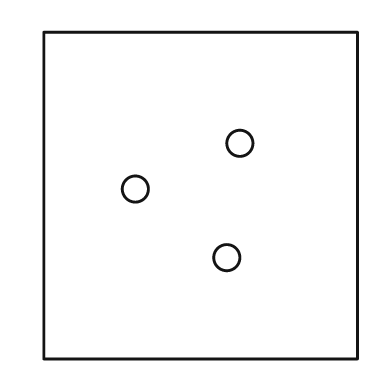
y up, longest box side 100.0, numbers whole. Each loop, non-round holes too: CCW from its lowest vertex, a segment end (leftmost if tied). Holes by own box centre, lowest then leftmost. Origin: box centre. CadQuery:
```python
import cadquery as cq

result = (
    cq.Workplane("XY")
    .moveTo(-48.0, -50.0)
    .lineTo(48.0, -50.0)
    .lineTo(48.0, 50.0)
    .lineTo(-48.0, 50.0)
    .close()
    .moveTo(8.0, -19.0)
    .circle(4.0)
    .moveTo(-20.0, 2.0)
    .circle(4.0)
    .moveTo(12.0, 16.0)
    .circle(4.0)
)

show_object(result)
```